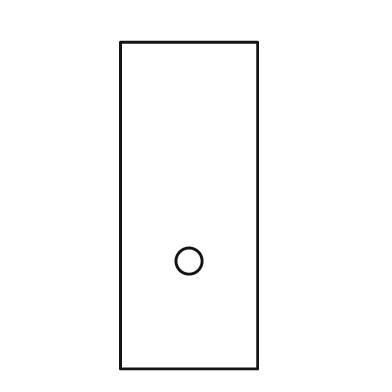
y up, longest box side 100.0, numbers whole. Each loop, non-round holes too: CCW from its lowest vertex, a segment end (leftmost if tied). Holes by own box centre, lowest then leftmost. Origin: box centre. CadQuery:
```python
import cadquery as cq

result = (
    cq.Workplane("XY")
    .moveTo(-21.0, -50.0)
    .lineTo(21.0, -50.0)
    .lineTo(21.0, 50.0)
    .lineTo(-21.0, 50.0)
    .close()
    .moveTo(0.0, -17.0)
    .circle(4.0)
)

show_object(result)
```